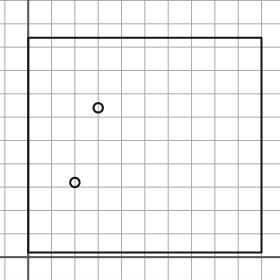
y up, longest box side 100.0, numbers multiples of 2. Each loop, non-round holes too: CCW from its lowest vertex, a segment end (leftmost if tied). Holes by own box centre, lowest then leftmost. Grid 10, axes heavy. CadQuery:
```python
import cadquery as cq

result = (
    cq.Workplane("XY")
    .moveTo(0.0, 2.0)
    .lineTo(100.0, 2.0)
    .lineTo(100.0, 94.0)
    .lineTo(0.0, 94.0)
    .close()
    .moveTo(20.0, 32.0)
    .circle(2.0)
    .moveTo(30.0, 64.0)
    .circle(2.0)
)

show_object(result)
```